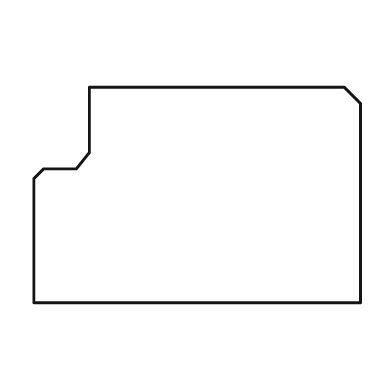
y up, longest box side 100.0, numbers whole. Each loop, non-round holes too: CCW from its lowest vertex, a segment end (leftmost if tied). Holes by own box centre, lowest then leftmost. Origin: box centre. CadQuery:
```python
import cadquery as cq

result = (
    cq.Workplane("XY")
    .moveTo(-50.0, -33.0)
    .lineTo(50.0, -33.0)
    .lineTo(50.0, 28.0)
    .lineTo(45.0, 33.0)
    .lineTo(-33.0, 33.0)
    .lineTo(-33.0, 13.0)
    .lineTo(-37.0, 8.0)
    .lineTo(-47.0, 8.0)
    .lineTo(-50.0, 5.0)
    .close()
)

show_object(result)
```